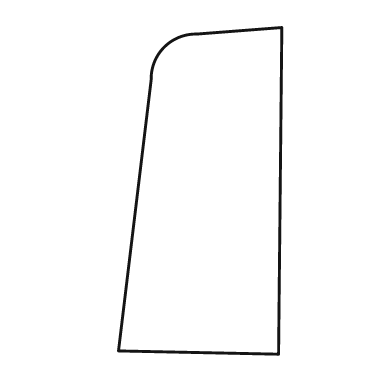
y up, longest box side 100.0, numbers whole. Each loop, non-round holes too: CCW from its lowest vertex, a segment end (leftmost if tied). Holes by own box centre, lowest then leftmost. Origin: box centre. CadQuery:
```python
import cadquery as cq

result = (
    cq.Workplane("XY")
    .moveTo(24.0, -50.0)
    .lineTo(25.0, 50.0)
    .lineTo(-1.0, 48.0)
    .threePointArc((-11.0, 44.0), (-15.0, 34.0))
    .lineTo(-25.0, -49.0)
    .close()
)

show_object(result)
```